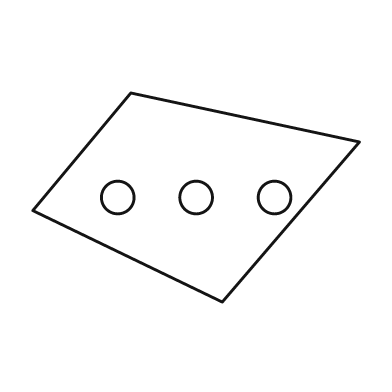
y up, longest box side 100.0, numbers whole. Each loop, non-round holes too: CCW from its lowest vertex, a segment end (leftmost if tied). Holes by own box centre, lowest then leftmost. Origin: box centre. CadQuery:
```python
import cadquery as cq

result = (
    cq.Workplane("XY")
    .moveTo(8.0, -32.0)
    .lineTo(50.0, 17.0)
    .lineTo(-20.0, 32.0)
    .lineTo(-50.0, -4.0)
    .close()
    .moveTo(-24.0, 0.0)
    .circle(5.0)
    .moveTo(0.0, 0.0)
    .circle(5.0)
    .moveTo(24.0, 0.0)
    .circle(5.0)
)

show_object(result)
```